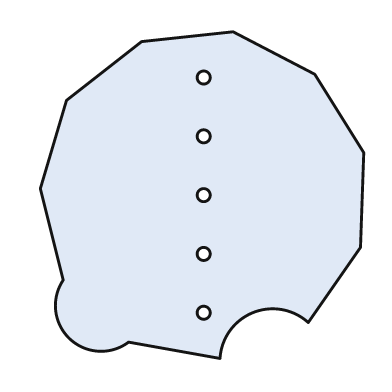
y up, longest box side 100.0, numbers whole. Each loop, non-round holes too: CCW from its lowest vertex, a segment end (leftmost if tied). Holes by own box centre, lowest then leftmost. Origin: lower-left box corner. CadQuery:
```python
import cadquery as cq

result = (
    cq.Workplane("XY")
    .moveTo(55.0, 0.0)
    .threePointArc((65.0, 14.0), (82.0, 11.0))
    .lineTo(98.0, 34.0)
    .lineTo(99.0, 63.0)
    .lineTo(84.0, 87.0)
    .lineTo(59.0, 100.0)
    .lineTo(31.0, 97.0)
    .lineTo(8.0, 79.0)
    .lineTo(0.0, 52.0)
    .lineTo(7.0, 24.0)
    .threePointArc((9.0, 6.0), (27.0, 5.0))
    .close()
    .moveTo(50.0, 14.0)
    .circle(2.0)
    .moveTo(50.0, 32.0)
    .circle(2.0)
    .moveTo(50.0, 50.0)
    .circle(2.0)
    .moveTo(50.0, 68.0)
    .circle(2.0)
    .moveTo(50.0, 86.0)
    .circle(2.0)
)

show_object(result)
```